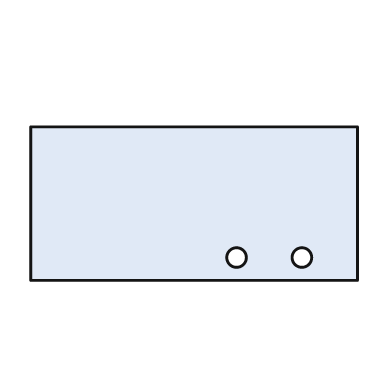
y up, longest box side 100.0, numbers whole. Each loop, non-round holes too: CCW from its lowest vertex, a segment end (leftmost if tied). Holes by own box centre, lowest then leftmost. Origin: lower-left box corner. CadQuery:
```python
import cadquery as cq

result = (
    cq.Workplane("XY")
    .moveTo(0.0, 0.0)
    .lineTo(100.0, 0.0)
    .lineTo(100.0, 47.0)
    .lineTo(0.0, 47.0)
    .close()
    .moveTo(63.0, 7.0)
    .circle(3.0)
    .moveTo(83.0, 7.0)
    .circle(3.0)
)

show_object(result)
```